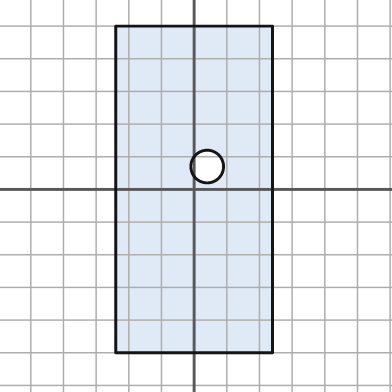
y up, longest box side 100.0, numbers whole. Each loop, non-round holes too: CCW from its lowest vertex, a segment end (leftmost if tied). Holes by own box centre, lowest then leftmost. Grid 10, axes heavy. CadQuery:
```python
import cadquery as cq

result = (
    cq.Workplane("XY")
    .moveTo(-24.0, -50.0)
    .lineTo(24.0, -50.0)
    .lineTo(24.0, 50.0)
    .lineTo(-24.0, 50.0)
    .close()
    .moveTo(4.0, 7.0)
    .circle(5.0)
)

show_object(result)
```